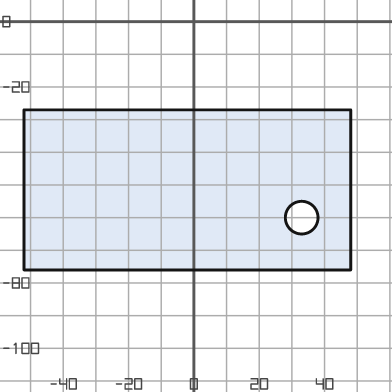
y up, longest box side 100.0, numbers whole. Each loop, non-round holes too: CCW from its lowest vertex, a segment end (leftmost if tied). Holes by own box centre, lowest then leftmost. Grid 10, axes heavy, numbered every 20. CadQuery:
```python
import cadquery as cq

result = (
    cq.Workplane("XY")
    .moveTo(-52.0, -76.0)
    .lineTo(48.0, -76.0)
    .lineTo(48.0, -27.0)
    .lineTo(-52.0, -27.0)
    .close()
    .moveTo(33.0, -60.0)
    .circle(5.0)
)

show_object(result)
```